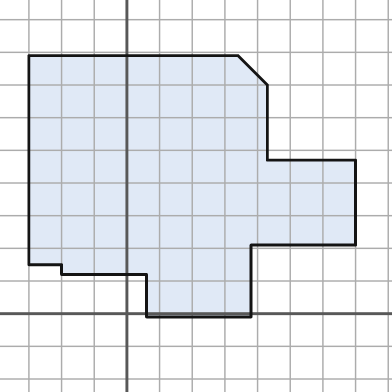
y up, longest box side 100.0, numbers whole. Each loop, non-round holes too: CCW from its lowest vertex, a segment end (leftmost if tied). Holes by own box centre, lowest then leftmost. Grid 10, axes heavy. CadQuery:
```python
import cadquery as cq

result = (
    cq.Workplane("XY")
    .moveTo(6.0, -1.0)
    .lineTo(38.0, -1.0)
    .lineTo(38.0, 21.0)
    .lineTo(70.0, 21.0)
    .lineTo(70.0, 47.0)
    .lineTo(43.0, 47.0)
    .lineTo(43.0, 70.0)
    .lineTo(34.0, 79.0)
    .lineTo(-30.0, 79.0)
    .lineTo(-30.0, 15.0)
    .lineTo(-20.0, 15.0)
    .lineTo(-20.0, 12.0)
    .lineTo(6.0, 12.0)
    .close()
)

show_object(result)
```